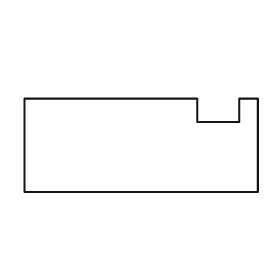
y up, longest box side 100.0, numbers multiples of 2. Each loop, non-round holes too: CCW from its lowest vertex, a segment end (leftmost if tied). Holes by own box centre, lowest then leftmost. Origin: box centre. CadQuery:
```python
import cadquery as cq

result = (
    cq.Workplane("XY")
    .moveTo(-50.0, -20.0)
    .lineTo(50.0, -20.0)
    .lineTo(50.0, 20.0)
    .lineTo(42.0, 20.0)
    .lineTo(42.0, 10.0)
    .lineTo(24.0, 10.0)
    .lineTo(24.0, 20.0)
    .lineTo(-50.0, 20.0)
    .close()
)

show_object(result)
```